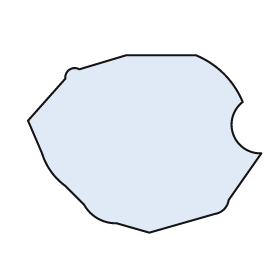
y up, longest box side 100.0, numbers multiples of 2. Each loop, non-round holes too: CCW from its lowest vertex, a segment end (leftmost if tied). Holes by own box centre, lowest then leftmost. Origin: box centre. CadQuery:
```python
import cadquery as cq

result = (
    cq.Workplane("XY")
    .moveTo(2.0, -38.0)
    .lineTo(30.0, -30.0)
    .threePointArc((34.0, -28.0), (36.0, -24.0))
    .lineTo(50.0, -4.0)
    .threePointArc((38.0, 4.0), (42.0, 18.0))
    .threePointArc((34.0, 30.0), (22.0, 38.0))
    .lineTo(-8.0, 38.0)
    .lineTo(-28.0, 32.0)
    .threePointArc((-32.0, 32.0), (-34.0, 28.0))
    .lineTo(-50.0, 10.0)
    .lineTo(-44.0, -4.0)
    .threePointArc((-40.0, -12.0), (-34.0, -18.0))
    .lineTo(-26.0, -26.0)
    .threePointArc((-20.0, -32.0), (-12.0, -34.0))
    .close()
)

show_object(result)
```